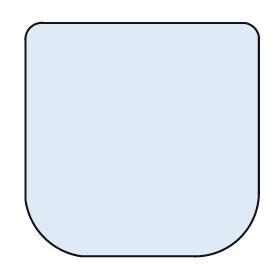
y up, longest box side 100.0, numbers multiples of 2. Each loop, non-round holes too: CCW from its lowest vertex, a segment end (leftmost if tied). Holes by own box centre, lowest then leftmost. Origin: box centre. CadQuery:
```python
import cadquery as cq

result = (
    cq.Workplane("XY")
    .moveTo(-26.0, -50.0)
    .lineTo(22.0, -50.0)
    .threePointArc((42.0, -42.0), (50.0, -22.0))
    .lineTo(50.0, 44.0)
    .threePointArc((48.0, 48.0), (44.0, 50.0))
    .lineTo(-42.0, 50.0)
    .threePointArc((-48.0, 48.0), (-50.0, 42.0))
    .lineTo(-50.0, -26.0)
    .threePointArc((-42.0, -42.0), (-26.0, -50.0))
    .close()
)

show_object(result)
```